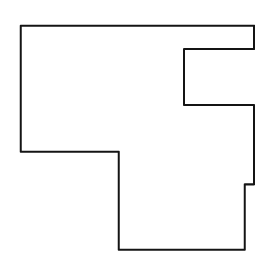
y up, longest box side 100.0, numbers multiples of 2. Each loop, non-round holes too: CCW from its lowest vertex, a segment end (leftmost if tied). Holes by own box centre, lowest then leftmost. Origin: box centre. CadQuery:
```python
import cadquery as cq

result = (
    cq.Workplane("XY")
    .moveTo(-8.0, -48.0)
    .lineTo(46.0, -48.0)
    .lineTo(46.0, -20.0)
    .lineTo(50.0, -20.0)
    .lineTo(50.0, 14.0)
    .lineTo(20.0, 14.0)
    .lineTo(20.0, 38.0)
    .lineTo(50.0, 38.0)
    .lineTo(50.0, 48.0)
    .lineTo(-50.0, 48.0)
    .lineTo(-50.0, -6.0)
    .lineTo(-8.0, -6.0)
    .close()
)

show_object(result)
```